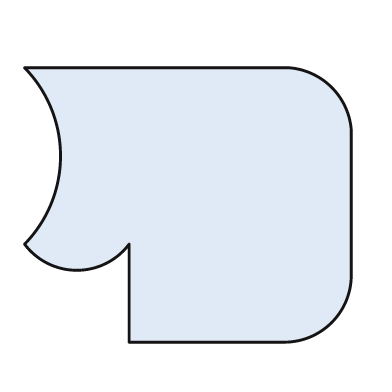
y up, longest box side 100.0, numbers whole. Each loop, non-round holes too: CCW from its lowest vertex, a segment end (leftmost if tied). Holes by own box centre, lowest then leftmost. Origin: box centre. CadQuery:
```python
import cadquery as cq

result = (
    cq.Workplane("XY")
    .moveTo(-18.0, -42.0)
    .lineTo(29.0, -42.0)
    .threePointArc((44.0, -36.0), (50.0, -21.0))
    .lineTo(50.0, 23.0)
    .threePointArc((44.0, 36.0), (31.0, 42.0))
    .lineTo(-50.0, 42.0)
    .threePointArc((-39.0, 15.0), (-50.0, -12.0))
    .threePointArc((-34.0, -20.0), (-18.0, -12.0))
    .close()
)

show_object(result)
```